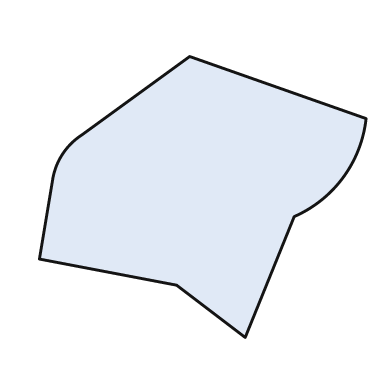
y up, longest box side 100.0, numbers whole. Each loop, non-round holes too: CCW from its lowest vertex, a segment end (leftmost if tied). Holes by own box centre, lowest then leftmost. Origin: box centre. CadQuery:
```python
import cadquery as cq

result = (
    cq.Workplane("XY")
    .moveTo(13.0, -43.0)
    .lineTo(28.0, -6.0)
    .threePointArc((43.0, 6.0), (50.0, 24.0))
    .lineTo(-4.0, 43.0)
    .lineTo(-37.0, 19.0)
    .threePointArc((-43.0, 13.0), (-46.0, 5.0))
    .lineTo(-50.0, -19.0)
    .lineTo(-8.0, -27.0)
    .close()
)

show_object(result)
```